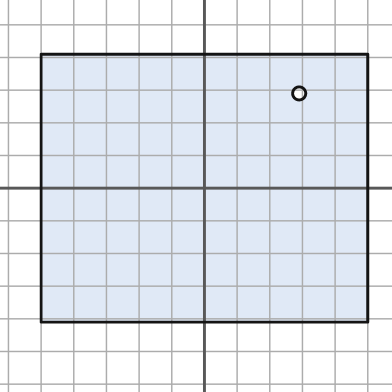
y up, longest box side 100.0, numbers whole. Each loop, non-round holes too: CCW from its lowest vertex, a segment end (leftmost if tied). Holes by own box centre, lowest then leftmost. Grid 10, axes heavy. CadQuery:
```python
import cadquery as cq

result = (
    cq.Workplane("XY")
    .moveTo(-50.0, -41.0)
    .lineTo(50.0, -41.0)
    .lineTo(50.0, 41.0)
    .lineTo(-50.0, 41.0)
    .close()
    .moveTo(29.0, 29.0)
    .circle(2.0)
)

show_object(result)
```